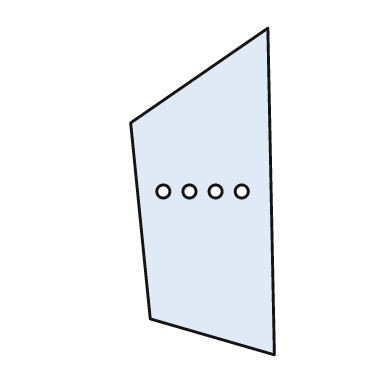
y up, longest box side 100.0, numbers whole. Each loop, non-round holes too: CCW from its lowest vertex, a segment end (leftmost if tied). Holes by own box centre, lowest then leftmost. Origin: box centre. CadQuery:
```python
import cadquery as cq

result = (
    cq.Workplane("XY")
    .moveTo(22.0, -50.0)
    .lineTo(20.0, 50.0)
    .lineTo(-22.0, 21.0)
    .lineTo(-16.0, -39.0)
    .close()
    .moveTo(-12.0, 0.0)
    .circle(2.0)
    .moveTo(-4.0, 0.0)
    .circle(2.0)
    .moveTo(4.0, 0.0)
    .circle(2.0)
    .moveTo(12.0, 0.0)
    .circle(2.0)
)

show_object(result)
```